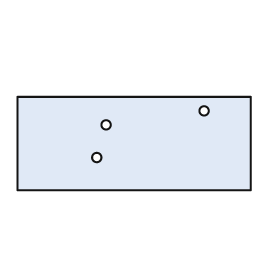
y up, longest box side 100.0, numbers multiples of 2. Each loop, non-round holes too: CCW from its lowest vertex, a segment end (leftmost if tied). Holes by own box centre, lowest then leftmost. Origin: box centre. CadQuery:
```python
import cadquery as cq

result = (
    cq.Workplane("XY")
    .moveTo(-50.0, -20.0)
    .lineTo(50.0, -20.0)
    .lineTo(50.0, 20.0)
    .lineTo(-50.0, 20.0)
    .close()
    .moveTo(-16.0, -6.0)
    .circle(2.0)
    .moveTo(-12.0, 8.0)
    .circle(2.0)
    .moveTo(30.0, 14.0)
    .circle(2.0)
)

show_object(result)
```